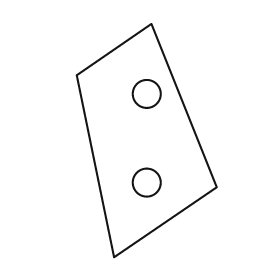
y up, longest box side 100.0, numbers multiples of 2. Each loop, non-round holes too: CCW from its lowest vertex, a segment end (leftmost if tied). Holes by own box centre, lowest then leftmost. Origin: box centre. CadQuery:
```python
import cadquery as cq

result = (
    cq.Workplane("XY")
    .moveTo(-14.0, -50.0)
    .lineTo(30.0, -20.0)
    .lineTo(2.0, 50.0)
    .lineTo(-30.0, 28.0)
    .close()
    .moveTo(0.0, -18.0)
    .circle(6.0)
    .moveTo(0.0, 20.0)
    .circle(6.0)
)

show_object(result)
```